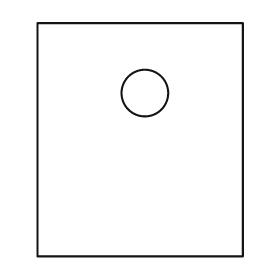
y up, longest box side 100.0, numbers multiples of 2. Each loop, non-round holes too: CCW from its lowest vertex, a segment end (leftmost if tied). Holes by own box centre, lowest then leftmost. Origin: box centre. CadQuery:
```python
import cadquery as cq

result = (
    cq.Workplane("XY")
    .moveTo(-44.0, -50.0)
    .lineTo(44.0, -50.0)
    .lineTo(44.0, 50.0)
    .lineTo(-44.0, 50.0)
    .close()
    .moveTo(2.0, 20.0)
    .circle(10.0)
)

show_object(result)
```